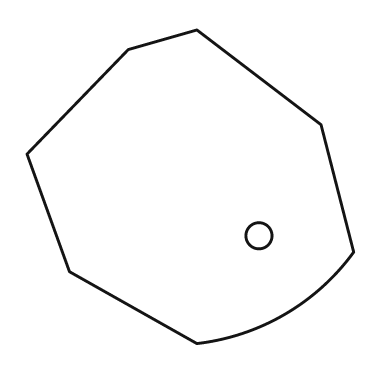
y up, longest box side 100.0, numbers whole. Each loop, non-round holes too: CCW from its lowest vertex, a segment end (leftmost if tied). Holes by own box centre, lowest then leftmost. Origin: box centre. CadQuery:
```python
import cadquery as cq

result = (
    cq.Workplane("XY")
    .moveTo(2.0, -48.0)
    .threePointArc((29.0, -39.0), (50.0, -20.0))
    .lineTo(40.0, 19.0)
    .lineTo(2.0, 48.0)
    .lineTo(-19.0, 42.0)
    .lineTo(-50.0, 10.0)
    .lineTo(-37.0, -26.0)
    .close()
    .moveTo(21.0, -15.0)
    .circle(4.0)
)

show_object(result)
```